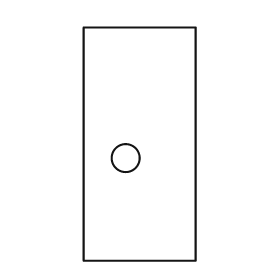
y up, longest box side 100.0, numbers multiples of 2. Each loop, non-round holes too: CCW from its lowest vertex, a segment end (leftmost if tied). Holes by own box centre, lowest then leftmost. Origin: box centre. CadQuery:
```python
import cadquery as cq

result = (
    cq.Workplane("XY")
    .moveTo(-24.0, -50.0)
    .lineTo(24.0, -50.0)
    .lineTo(24.0, 50.0)
    .lineTo(-24.0, 50.0)
    .close()
    .moveTo(-6.0, -6.0)
    .circle(6.0)
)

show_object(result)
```